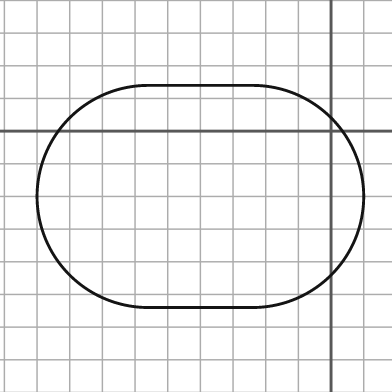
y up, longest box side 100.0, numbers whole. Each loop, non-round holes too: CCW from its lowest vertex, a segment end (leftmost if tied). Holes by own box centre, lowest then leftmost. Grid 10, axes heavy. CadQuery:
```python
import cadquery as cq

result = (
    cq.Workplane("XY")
    .moveTo(-56.0, -54.0)
    .lineTo(-24.0, -54.0)
    .threePointArc((10.0, -20.0), (-24.0, 14.0))
    .lineTo(-56.0, 14.0)
    .threePointArc((-90.0, -20.0), (-56.0, -54.0))
    .close()
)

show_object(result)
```